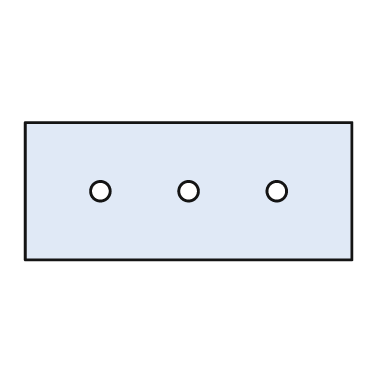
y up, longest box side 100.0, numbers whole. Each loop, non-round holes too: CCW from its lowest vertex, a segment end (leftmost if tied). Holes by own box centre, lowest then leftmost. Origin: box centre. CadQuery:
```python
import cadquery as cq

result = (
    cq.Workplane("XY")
    .moveTo(-50.0, -21.0)
    .lineTo(50.0, -21.0)
    .lineTo(50.0, 21.0)
    .lineTo(-50.0, 21.0)
    .close()
    .moveTo(-27.0, 0.0)
    .circle(3.0)
    .moveTo(0.0, 0.0)
    .circle(3.0)
    .moveTo(27.0, 0.0)
    .circle(3.0)
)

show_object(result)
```